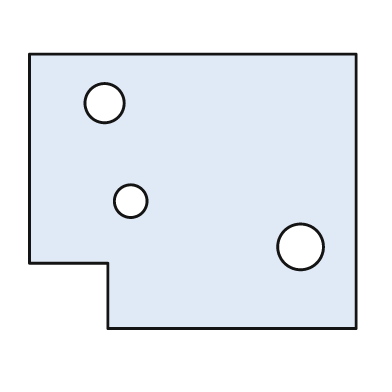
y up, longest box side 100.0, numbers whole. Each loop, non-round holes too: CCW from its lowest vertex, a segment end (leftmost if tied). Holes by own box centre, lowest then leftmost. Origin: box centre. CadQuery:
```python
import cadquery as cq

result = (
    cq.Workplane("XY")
    .moveTo(-26.0, -42.0)
    .lineTo(50.0, -42.0)
    .lineTo(50.0, 42.0)
    .lineTo(-50.0, 42.0)
    .lineTo(-50.0, -22.0)
    .lineTo(-26.0, -22.0)
    .close()
    .moveTo(33.0, -17.0)
    .circle(7.0)
    .moveTo(-19.0, -3.0)
    .circle(5.0)
    .moveTo(-27.0, 27.0)
    .circle(6.0)
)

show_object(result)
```